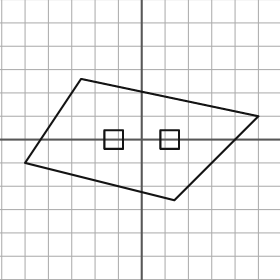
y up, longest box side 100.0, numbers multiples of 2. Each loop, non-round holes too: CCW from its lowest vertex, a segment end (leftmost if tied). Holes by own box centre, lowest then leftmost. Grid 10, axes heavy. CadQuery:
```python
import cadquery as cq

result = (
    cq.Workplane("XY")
    .moveTo(14.0, -26.0)
    .lineTo(50.0, 10.0)
    .lineTo(-26.0, 26.0)
    .lineTo(-50.0, -10.0)
    .close()
    .moveTo(-16.0, -4.0)
    .lineTo(-8.0, -4.0)
    .lineTo(-8.0, 4.0)
    .lineTo(-16.0, 4.0)
    .close()
    .moveTo(8.0, -4.0)
    .lineTo(16.0, -4.0)
    .lineTo(16.0, 4.0)
    .lineTo(8.0, 4.0)
    .close()
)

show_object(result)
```